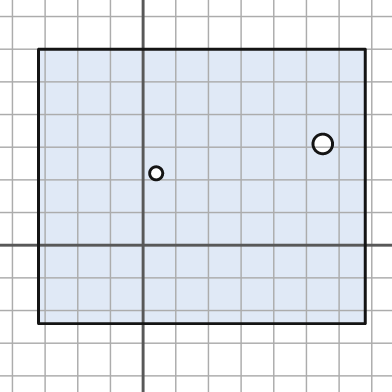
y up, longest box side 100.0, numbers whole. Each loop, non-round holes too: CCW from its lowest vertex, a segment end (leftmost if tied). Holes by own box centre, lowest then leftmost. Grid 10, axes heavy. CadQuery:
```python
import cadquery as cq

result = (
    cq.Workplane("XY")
    .moveTo(-32.0, -24.0)
    .lineTo(68.0, -24.0)
    .lineTo(68.0, 60.0)
    .lineTo(-32.0, 60.0)
    .close()
    .moveTo(4.0, 22.0)
    .circle(2.0)
    .moveTo(55.0, 31.0)
    .circle(3.0)
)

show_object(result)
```